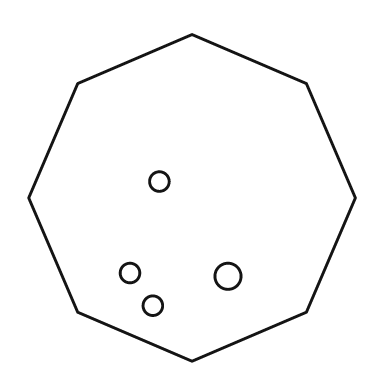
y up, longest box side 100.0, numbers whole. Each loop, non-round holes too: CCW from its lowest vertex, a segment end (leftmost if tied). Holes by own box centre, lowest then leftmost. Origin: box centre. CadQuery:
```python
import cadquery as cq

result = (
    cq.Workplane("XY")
    .moveTo(0.0, -50.0)
    .lineTo(35.0, -35.0)
    .lineTo(50.0, 0.0)
    .lineTo(35.0, 35.0)
    .lineTo(0.0, 50.0)
    .lineTo(-35.0, 35.0)
    .lineTo(-50.0, 0.0)
    .lineTo(-35.0, -35.0)
    .close()
    .moveTo(-12.0, -33.0)
    .circle(3.0)
    .moveTo(11.0, -24.0)
    .circle(4.0)
    .moveTo(-19.0, -23.0)
    .circle(3.0)
    .moveTo(-10.0, 5.0)
    .circle(3.0)
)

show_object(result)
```